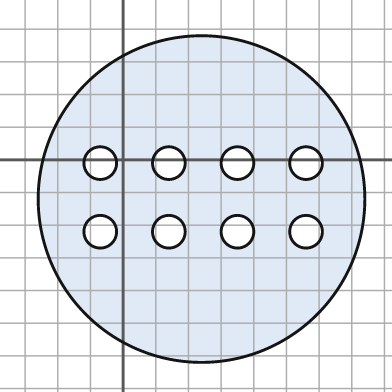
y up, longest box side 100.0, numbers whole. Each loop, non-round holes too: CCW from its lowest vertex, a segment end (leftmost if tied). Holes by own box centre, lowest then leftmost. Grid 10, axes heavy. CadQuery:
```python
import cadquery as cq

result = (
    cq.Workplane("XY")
    .moveTo(24.0, -12.0)
    .circle(50.0)
    .moveTo(-7.0, -22.0)
    .circle(5.0)
    .moveTo(14.0, -22.0)
    .circle(5.0)
    .moveTo(35.0, -22.0)
    .circle(5.0)
    .moveTo(56.0, -22.0)
    .circle(5.0)
    .moveTo(-7.0, -1.0)
    .circle(5.0)
    .moveTo(14.0, -1.0)
    .circle(5.0)
    .moveTo(35.0, -1.0)
    .circle(5.0)
    .moveTo(56.0, -1.0)
    .circle(5.0)
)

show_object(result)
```